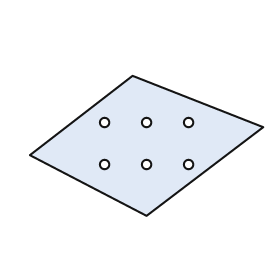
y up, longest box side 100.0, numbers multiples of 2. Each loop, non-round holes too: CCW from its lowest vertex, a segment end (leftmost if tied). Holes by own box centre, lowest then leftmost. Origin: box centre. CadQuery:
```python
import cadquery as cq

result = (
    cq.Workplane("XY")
    .moveTo(0.0, -30.0)
    .lineTo(50.0, 8.0)
    .lineTo(-6.0, 30.0)
    .lineTo(-50.0, -4.0)
    .close()
    .moveTo(-18.0, -8.0)
    .circle(2.0)
    .moveTo(0.0, -8.0)
    .circle(2.0)
    .moveTo(18.0, -8.0)
    .circle(2.0)
    .moveTo(-18.0, 10.0)
    .circle(2.0)
    .moveTo(0.0, 10.0)
    .circle(2.0)
    .moveTo(18.0, 10.0)
    .circle(2.0)
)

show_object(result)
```